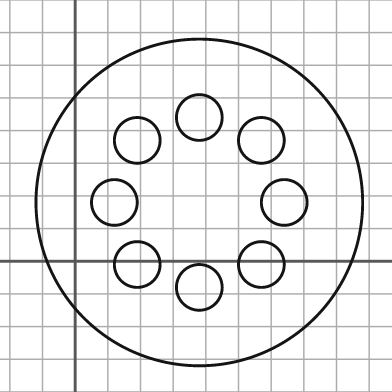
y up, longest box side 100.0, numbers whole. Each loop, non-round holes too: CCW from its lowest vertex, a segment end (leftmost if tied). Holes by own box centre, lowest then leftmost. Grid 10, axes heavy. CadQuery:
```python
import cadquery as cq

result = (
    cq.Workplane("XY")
    .moveTo(38.0, 18.0)
    .circle(50.0)
    .moveTo(38.0, -8.0)
    .circle(7.0)
    .moveTo(19.0, -1.0)
    .circle(7.0)
    .moveTo(57.0, -1.0)
    .circle(7.0)
    .moveTo(12.0, 18.0)
    .circle(7.0)
    .moveTo(64.0, 18.0)
    .circle(7.0)
    .moveTo(19.0, 37.0)
    .circle(7.0)
    .moveTo(57.0, 37.0)
    .circle(7.0)
    .moveTo(38.0, 44.0)
    .circle(7.0)
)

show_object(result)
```